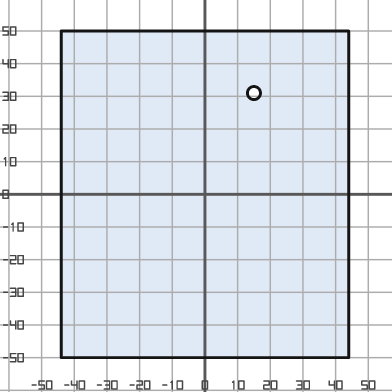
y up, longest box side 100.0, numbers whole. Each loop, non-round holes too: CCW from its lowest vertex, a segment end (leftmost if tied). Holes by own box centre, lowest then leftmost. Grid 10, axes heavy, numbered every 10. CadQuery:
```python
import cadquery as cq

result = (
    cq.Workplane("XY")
    .moveTo(-44.0, -50.0)
    .lineTo(44.0, -50.0)
    .lineTo(44.0, 50.0)
    .lineTo(-44.0, 50.0)
    .close()
    .moveTo(15.0, 31.0)
    .circle(2.0)
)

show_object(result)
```